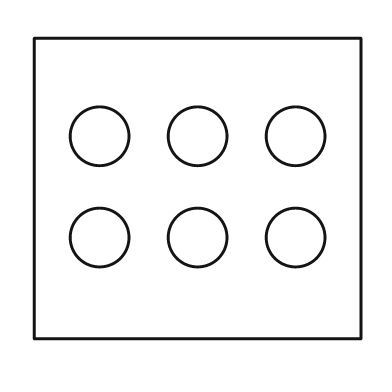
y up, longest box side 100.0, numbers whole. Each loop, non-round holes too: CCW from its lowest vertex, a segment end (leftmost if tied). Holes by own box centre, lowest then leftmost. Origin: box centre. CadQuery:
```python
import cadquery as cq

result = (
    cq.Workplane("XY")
    .moveTo(-50.0, -46.0)
    .lineTo(50.0, -46.0)
    .lineTo(50.0, 46.0)
    .lineTo(-50.0, 46.0)
    .close()
    .moveTo(-30.0, -15.0)
    .circle(9.0)
    .moveTo(0.0, -15.0)
    .circle(9.0)
    .moveTo(30.0, -15.0)
    .circle(9.0)
    .moveTo(-30.0, 16.0)
    .circle(9.0)
    .moveTo(0.0, 16.0)
    .circle(9.0)
    .moveTo(30.0, 16.0)
    .circle(9.0)
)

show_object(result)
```